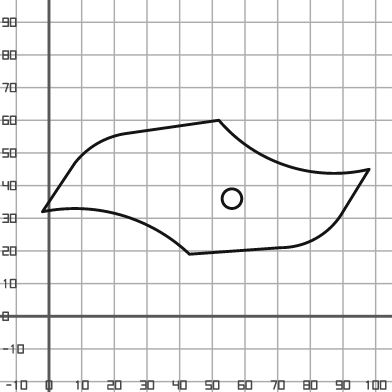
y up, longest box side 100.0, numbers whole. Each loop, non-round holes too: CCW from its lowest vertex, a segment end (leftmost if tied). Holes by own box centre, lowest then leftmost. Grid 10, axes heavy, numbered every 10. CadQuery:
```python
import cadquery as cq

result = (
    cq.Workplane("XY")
    .moveTo(43.0, 19.0)
    .lineTo(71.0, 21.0)
    .threePointArc((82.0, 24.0), (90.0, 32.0))
    .lineTo(98.0, 45.0)
    .threePointArc((73.0, 46.0), (52.0, 60.0))
    .lineTo(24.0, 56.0)
    .threePointArc((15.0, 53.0), (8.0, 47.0))
    .lineTo(-2.0, 32.0)
    .threePointArc((22.0, 31.0), (43.0, 19.0))
    .close()
    .moveTo(56.0, 36.0)
    .circle(3.0)
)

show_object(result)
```